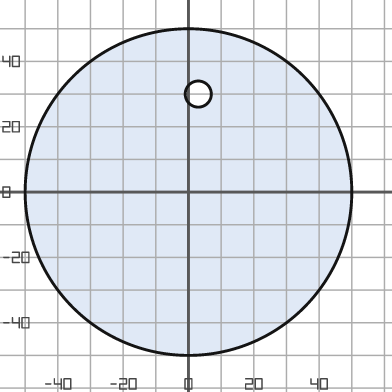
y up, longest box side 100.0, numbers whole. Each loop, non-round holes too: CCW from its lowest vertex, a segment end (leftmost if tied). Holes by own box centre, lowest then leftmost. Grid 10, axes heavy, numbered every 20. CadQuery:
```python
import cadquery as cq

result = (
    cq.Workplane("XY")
    .moveTo(0.0, 0.0)
    .circle(50.0)
    .moveTo(3.0, 30.0)
    .circle(4.0)
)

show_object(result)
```